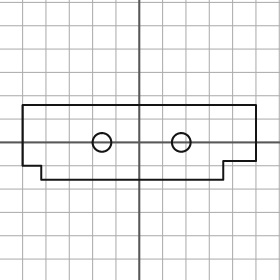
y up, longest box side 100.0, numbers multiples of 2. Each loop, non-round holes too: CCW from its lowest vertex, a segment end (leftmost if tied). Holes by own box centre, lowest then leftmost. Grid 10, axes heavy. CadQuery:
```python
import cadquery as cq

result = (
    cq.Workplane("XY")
    .moveTo(-42.0, -16.0)
    .lineTo(36.0, -16.0)
    .lineTo(36.0, -8.0)
    .lineTo(50.0, -8.0)
    .lineTo(50.0, 16.0)
    .lineTo(-50.0, 16.0)
    .lineTo(-50.0, -10.0)
    .lineTo(-42.0, -10.0)
    .close()
    .moveTo(-16.0, 0.0)
    .circle(4.0)
    .moveTo(18.0, 0.0)
    .circle(4.0)
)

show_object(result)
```